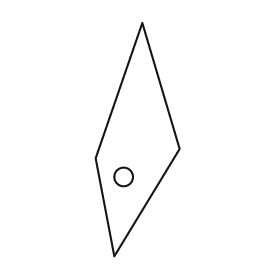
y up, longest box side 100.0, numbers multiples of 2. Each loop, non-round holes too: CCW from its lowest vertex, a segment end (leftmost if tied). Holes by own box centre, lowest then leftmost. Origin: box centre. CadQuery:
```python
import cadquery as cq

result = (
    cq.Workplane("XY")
    .moveTo(-10.0, -50.0)
    .lineTo(18.0, -4.0)
    .lineTo(2.0, 50.0)
    .lineTo(-18.0, -8.0)
    .close()
    .moveTo(-6.0, -16.0)
    .circle(4.0)
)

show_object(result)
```